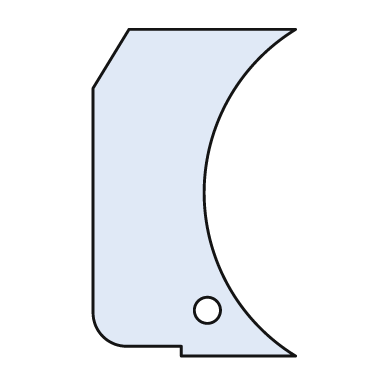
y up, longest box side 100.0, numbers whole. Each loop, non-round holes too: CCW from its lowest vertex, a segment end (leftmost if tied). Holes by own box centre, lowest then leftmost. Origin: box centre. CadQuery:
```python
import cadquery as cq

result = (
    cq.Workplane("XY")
    .moveTo(-4.0, -50.0)
    .lineTo(31.0, -50.0)
    .threePointArc((3.0, 0.0), (31.0, 50.0))
    .lineTo(-20.0, 50.0)
    .lineTo(-31.0, 32.0)
    .lineTo(-31.0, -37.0)
    .threePointArc((-28.0, -44.0), (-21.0, -47.0))
    .lineTo(-4.0, -47.0)
    .close()
    .moveTo(4.0, -36.0)
    .circle(4.0)
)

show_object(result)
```